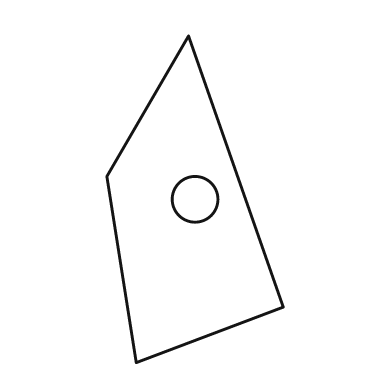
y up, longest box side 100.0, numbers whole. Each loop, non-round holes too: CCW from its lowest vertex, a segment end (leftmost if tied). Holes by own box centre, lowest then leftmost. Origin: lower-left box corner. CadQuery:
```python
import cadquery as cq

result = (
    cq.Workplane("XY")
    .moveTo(9.0, 0.0)
    .lineTo(54.0, 17.0)
    .lineTo(25.0, 100.0)
    .lineTo(0.0, 57.0)
    .close()
    .moveTo(27.0, 50.0)
    .circle(7.0)
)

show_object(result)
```